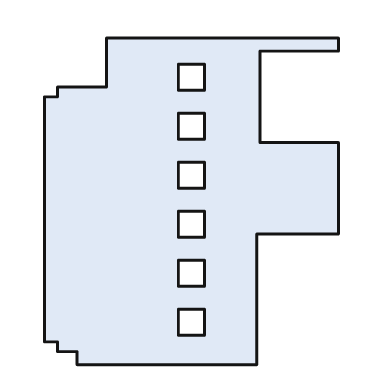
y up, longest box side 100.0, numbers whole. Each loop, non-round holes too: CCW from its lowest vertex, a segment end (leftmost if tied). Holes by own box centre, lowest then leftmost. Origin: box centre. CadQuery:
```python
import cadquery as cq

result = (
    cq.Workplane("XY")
    .moveTo(-35.0, -50.0)
    .lineTo(20.0, -50.0)
    .lineTo(20.0, -10.0)
    .lineTo(45.0, -10.0)
    .lineTo(45.0, 18.0)
    .lineTo(21.0, 18.0)
    .lineTo(21.0, 46.0)
    .lineTo(45.0, 46.0)
    .lineTo(45.0, 50.0)
    .lineTo(-26.0, 50.0)
    .lineTo(-26.0, 35.0)
    .lineTo(-41.0, 35.0)
    .lineTo(-41.0, 32.0)
    .lineTo(-45.0, 32.0)
    .lineTo(-45.0, -43.0)
    .lineTo(-41.0, -43.0)
    .lineTo(-41.0, -46.0)
    .lineTo(-35.0, -46.0)
    .close()
    .moveTo(-4.0, -41.0)
    .lineTo(4.0, -41.0)
    .lineTo(4.0, -33.0)
    .lineTo(-4.0, -33.0)
    .close()
    .moveTo(-4.0, -26.0)
    .lineTo(4.0, -26.0)
    .lineTo(4.0, -18.0)
    .lineTo(-4.0, -18.0)
    .close()
    .moveTo(-4.0, -11.0)
    .lineTo(4.0, -11.0)
    .lineTo(4.0, -3.0)
    .lineTo(-4.0, -3.0)
    .close()
    .moveTo(-4.0, 4.0)
    .lineTo(4.0, 4.0)
    .lineTo(4.0, 12.0)
    .lineTo(-4.0, 12.0)
    .close()
    .moveTo(-4.0, 19.0)
    .lineTo(4.0, 19.0)
    .lineTo(4.0, 27.0)
    .lineTo(-4.0, 27.0)
    .close()
    .moveTo(-4.0, 34.0)
    .lineTo(4.0, 34.0)
    .lineTo(4.0, 42.0)
    .lineTo(-4.0, 42.0)
    .close()
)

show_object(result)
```